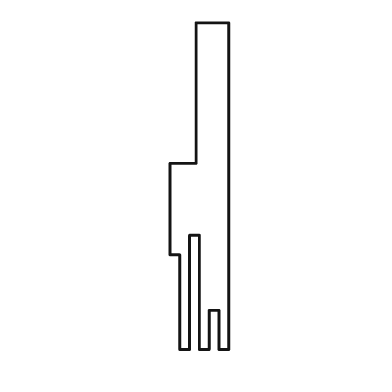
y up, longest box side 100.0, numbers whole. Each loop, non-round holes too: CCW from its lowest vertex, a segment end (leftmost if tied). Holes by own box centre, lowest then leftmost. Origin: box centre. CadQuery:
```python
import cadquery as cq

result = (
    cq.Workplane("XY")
    .moveTo(-6.0, -50.0)
    .lineTo(-3.0, -50.0)
    .lineTo(-3.0, -15.0)
    .lineTo(0.0, -15.0)
    .lineTo(0.0, -50.0)
    .lineTo(3.0, -50.0)
    .lineTo(3.0, -38.0)
    .lineTo(6.0, -38.0)
    .lineTo(6.0, -50.0)
    .lineTo(9.0, -50.0)
    .lineTo(9.0, 50.0)
    .lineTo(-1.0, 50.0)
    .lineTo(-1.0, 7.0)
    .lineTo(-9.0, 7.0)
    .lineTo(-9.0, -21.0)
    .lineTo(-6.0, -21.0)
    .close()
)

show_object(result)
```